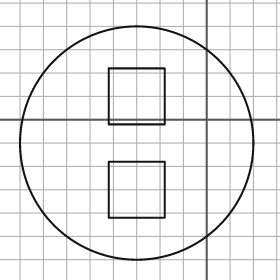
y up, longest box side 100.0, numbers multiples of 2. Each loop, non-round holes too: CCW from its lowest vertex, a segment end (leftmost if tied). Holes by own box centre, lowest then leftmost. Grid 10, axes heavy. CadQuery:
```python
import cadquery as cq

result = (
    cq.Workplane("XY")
    .moveTo(-30.0, -10.0)
    .circle(50.0)
    .moveTo(-42.0, -42.0)
    .lineTo(-18.0, -42.0)
    .lineTo(-18.0, -18.0)
    .lineTo(-42.0, -18.0)
    .close()
    .moveTo(-42.0, -2.0)
    .lineTo(-18.0, -2.0)
    .lineTo(-18.0, 22.0)
    .lineTo(-42.0, 22.0)
    .close()
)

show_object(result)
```